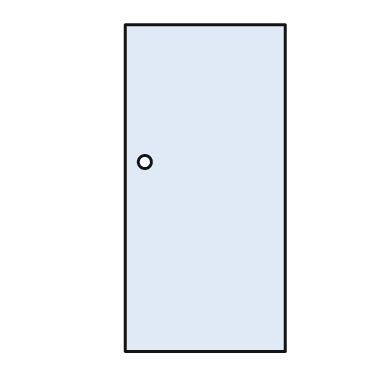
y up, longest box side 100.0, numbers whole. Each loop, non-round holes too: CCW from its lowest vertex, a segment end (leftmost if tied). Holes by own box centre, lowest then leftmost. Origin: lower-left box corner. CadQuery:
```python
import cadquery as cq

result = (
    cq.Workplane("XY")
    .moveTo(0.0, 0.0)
    .lineTo(49.0, 0.0)
    .lineTo(49.0, 100.0)
    .lineTo(0.0, 100.0)
    .close()
    .moveTo(6.0, 58.0)
    .circle(2.0)
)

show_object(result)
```